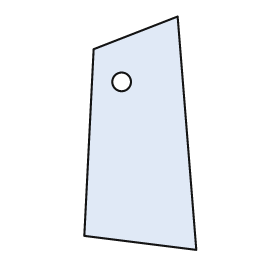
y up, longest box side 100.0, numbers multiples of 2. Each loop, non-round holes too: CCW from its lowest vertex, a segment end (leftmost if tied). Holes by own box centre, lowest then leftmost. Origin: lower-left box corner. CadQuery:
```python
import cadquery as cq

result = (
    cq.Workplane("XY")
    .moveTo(48.0, 0.0)
    .lineTo(40.0, 100.0)
    .lineTo(4.0, 86.0)
    .lineTo(0.0, 6.0)
    .close()
    .moveTo(16.0, 72.0)
    .circle(4.0)
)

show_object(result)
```